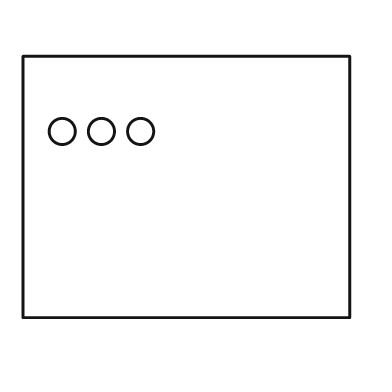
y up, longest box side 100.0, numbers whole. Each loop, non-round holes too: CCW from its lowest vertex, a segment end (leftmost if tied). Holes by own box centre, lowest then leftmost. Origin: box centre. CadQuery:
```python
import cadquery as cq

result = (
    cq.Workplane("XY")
    .moveTo(-50.0, -40.0)
    .lineTo(50.0, -40.0)
    .lineTo(50.0, 40.0)
    .lineTo(-50.0, 40.0)
    .close()
    .moveTo(-38.0, 17.0)
    .circle(4.0)
    .moveTo(-26.0, 17.0)
    .circle(4.0)
    .moveTo(-14.0, 17.0)
    .circle(4.0)
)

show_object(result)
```